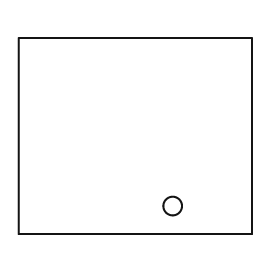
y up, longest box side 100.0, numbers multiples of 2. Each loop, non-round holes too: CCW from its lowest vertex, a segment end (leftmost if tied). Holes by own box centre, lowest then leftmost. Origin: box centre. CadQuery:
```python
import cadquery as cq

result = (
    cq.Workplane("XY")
    .moveTo(-50.0, -42.0)
    .lineTo(50.0, -42.0)
    .lineTo(50.0, 42.0)
    .lineTo(-50.0, 42.0)
    .close()
    .moveTo(16.0, -30.0)
    .circle(4.0)
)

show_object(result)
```